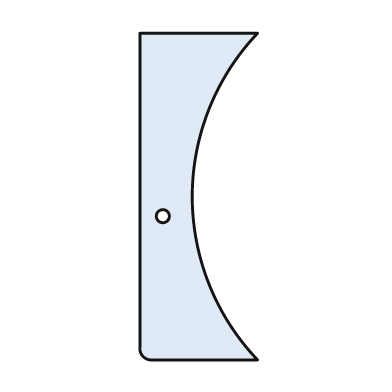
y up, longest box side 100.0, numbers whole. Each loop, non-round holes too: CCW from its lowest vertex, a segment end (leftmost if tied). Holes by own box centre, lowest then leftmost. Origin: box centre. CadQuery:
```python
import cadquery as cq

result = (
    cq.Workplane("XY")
    .moveTo(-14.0, -50.0)
    .lineTo(18.0, -50.0)
    .threePointArc((-2.0, 0.0), (18.0, 50.0))
    .lineTo(-18.0, 50.0)
    .lineTo(-18.0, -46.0)
    .threePointArc((-17.0, -49.0), (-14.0, -50.0))
    .close()
    .moveTo(-11.0, -6.0)
    .circle(2.0)
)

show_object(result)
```